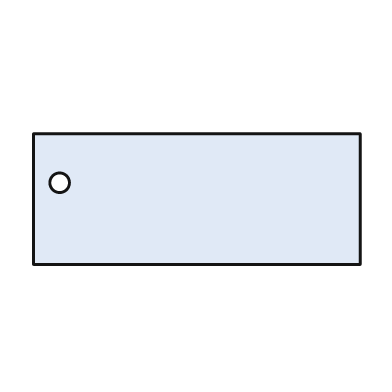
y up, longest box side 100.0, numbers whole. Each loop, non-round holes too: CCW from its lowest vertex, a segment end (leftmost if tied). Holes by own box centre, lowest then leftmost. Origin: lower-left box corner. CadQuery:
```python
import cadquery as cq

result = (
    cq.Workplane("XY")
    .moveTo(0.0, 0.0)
    .lineTo(100.0, 0.0)
    .lineTo(100.0, 40.0)
    .lineTo(0.0, 40.0)
    .close()
    .moveTo(8.0, 25.0)
    .circle(3.0)
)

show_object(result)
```